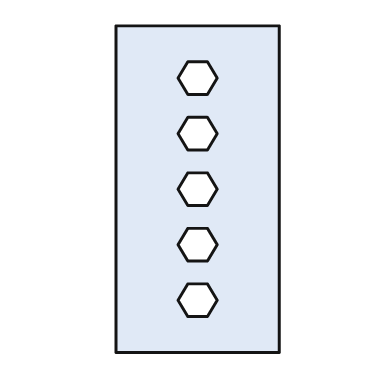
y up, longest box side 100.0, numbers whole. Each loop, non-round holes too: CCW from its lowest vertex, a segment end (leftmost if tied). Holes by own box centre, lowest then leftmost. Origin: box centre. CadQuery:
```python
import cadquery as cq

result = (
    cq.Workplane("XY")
    .moveTo(-25.0, -50.0)
    .lineTo(25.0, -50.0)
    .lineTo(25.0, 50.0)
    .lineTo(-25.0, 50.0)
    .close()
    .moveTo(-3.0, -39.0)
    .lineTo(3.0, -39.0)
    .lineTo(6.0, -34.0)
    .lineTo(3.0, -29.0)
    .lineTo(-3.0, -29.0)
    .lineTo(-6.0, -34.0)
    .close()
    .moveTo(-3.0, -22.0)
    .lineTo(3.0, -22.0)
    .lineTo(6.0, -17.0)
    .lineTo(3.0, -12.0)
    .lineTo(-3.0, -12.0)
    .lineTo(-6.0, -17.0)
    .close()
    .moveTo(-3.0, -5.0)
    .lineTo(3.0, -5.0)
    .lineTo(6.0, 0.0)
    .lineTo(3.0, 5.0)
    .lineTo(-3.0, 5.0)
    .lineTo(-6.0, 0.0)
    .close()
    .moveTo(-3.0, 12.0)
    .lineTo(3.0, 12.0)
    .lineTo(6.0, 17.0)
    .lineTo(3.0, 22.0)
    .lineTo(-3.0, 22.0)
    .lineTo(-6.0, 17.0)
    .close()
    .moveTo(-3.0, 29.0)
    .lineTo(3.0, 29.0)
    .lineTo(6.0, 34.0)
    .lineTo(3.0, 39.0)
    .lineTo(-3.0, 39.0)
    .lineTo(-6.0, 34.0)
    .close()
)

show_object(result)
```